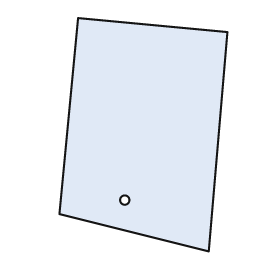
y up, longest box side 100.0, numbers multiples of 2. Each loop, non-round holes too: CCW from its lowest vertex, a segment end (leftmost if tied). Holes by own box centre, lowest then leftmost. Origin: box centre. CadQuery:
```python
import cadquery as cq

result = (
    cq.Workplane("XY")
    .moveTo(28.0, -50.0)
    .lineTo(36.0, 44.0)
    .lineTo(-28.0, 50.0)
    .lineTo(-36.0, -34.0)
    .close()
    .moveTo(-8.0, -28.0)
    .circle(2.0)
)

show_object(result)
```